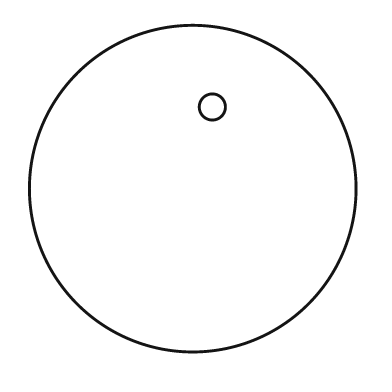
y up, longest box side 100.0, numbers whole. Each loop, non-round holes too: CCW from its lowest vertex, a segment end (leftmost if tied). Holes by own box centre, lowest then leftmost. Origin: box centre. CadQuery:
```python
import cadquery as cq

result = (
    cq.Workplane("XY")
    .moveTo(0.0, 0.0)
    .circle(50.0)
    .moveTo(6.0, 25.0)
    .circle(4.0)
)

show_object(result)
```